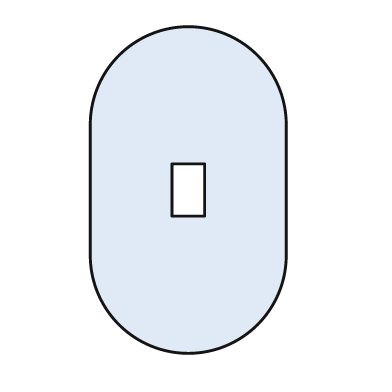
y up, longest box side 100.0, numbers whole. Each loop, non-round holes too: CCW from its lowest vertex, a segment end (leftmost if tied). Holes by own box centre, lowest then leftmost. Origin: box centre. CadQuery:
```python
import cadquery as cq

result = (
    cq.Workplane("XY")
    .moveTo(-30.0, -20.0)
    .threePointArc((0.0, -50.0), (30.0, -20.0))
    .lineTo(30.0, 20.0)
    .threePointArc((0.0, 50.0), (-30.0, 20.0))
    .close()
    .moveTo(-5.0, -8.0)
    .lineTo(5.0, -8.0)
    .lineTo(5.0, 8.0)
    .lineTo(-5.0, 8.0)
    .close()
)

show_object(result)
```